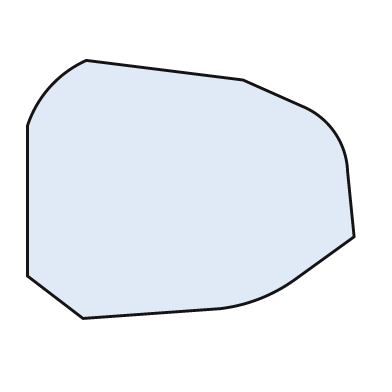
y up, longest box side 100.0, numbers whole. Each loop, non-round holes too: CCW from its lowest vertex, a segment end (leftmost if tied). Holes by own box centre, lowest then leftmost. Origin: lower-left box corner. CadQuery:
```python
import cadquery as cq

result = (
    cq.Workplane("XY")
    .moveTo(17.0, 0.0)
    .lineTo(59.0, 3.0)
    .threePointArc((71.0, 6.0), (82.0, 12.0))
    .lineTo(100.0, 25.0)
    .lineTo(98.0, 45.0)
    .threePointArc((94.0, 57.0), (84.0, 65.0))
    .lineTo(66.0, 73.0)
    .lineTo(18.0, 79.0)
    .threePointArc((7.0, 71.0), (0.0, 59.0))
    .lineTo(0.0, 13.0)
    .close()
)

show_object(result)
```